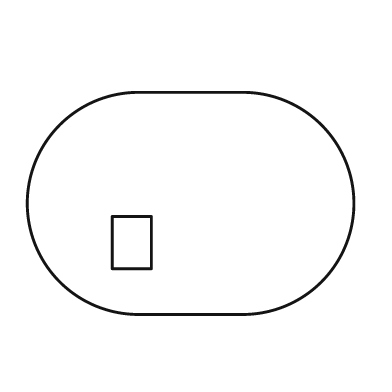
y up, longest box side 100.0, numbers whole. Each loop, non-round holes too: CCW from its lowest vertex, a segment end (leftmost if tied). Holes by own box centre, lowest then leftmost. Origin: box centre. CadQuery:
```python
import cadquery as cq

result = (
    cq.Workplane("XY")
    .moveTo(-16.0, -34.0)
    .lineTo(16.0, -34.0)
    .threePointArc((50.0, 0.0), (16.0, 34.0))
    .lineTo(-16.0, 34.0)
    .threePointArc((-50.0, 0.0), (-16.0, -34.0))
    .close()
    .moveTo(-24.0, -20.0)
    .lineTo(-12.0, -20.0)
    .lineTo(-12.0, -4.0)
    .lineTo(-24.0, -4.0)
    .close()
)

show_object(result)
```